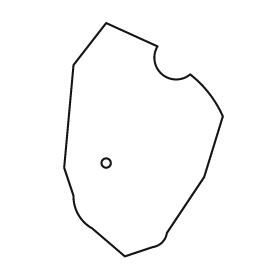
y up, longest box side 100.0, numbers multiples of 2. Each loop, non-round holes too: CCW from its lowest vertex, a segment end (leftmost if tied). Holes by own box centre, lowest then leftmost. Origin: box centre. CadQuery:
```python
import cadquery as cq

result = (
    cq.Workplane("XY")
    .moveTo(-8.0, -50.0)
    .lineTo(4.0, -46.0)
    .threePointArc((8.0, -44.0), (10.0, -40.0))
    .lineTo(26.0, -16.0)
    .lineTo(34.0, 10.0)
    .threePointArc((28.0, 20.0), (20.0, 28.0))
    .threePointArc((8.0, 28.0), (6.0, 40.0))
    .lineTo(-16.0, 50.0)
    .lineTo(-30.0, 32.0)
    .lineTo(-34.0, -12.0)
    .lineTo(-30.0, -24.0)
    .threePointArc((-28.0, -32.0), (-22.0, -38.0))
    .close()
    .moveTo(-16.0, -10.0)
    .circle(2.0)
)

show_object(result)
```